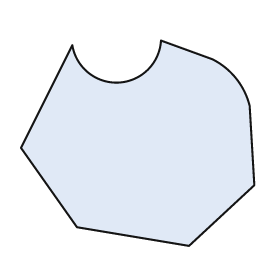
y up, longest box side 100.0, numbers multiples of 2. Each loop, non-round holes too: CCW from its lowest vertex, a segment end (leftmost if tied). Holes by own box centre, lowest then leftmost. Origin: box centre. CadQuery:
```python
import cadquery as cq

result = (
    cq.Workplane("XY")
    .moveTo(22.0, -44.0)
    .lineTo(50.0, -18.0)
    .lineTo(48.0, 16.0)
    .threePointArc((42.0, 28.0), (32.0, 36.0))
    .lineTo(10.0, 44.0)
    .threePointArc((-8.0, 26.0), (-28.0, 42.0))
    .lineTo(-50.0, -2.0)
    .lineTo(-26.0, -36.0)
    .close()
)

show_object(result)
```